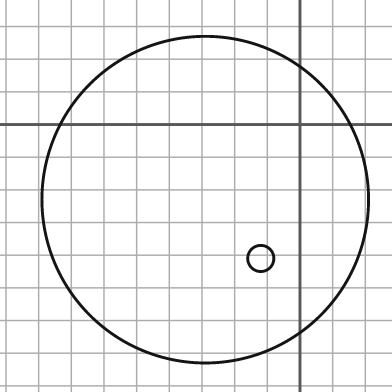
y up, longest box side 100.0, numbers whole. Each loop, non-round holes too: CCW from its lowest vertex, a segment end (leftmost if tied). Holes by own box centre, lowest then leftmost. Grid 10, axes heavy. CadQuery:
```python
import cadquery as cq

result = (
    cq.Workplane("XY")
    .moveTo(-29.0, -23.0)
    .circle(50.0)
    .moveTo(-12.0, -41.0)
    .circle(4.0)
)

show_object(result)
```